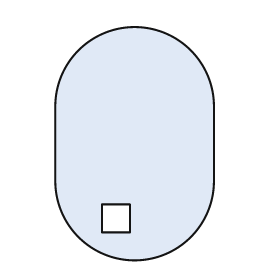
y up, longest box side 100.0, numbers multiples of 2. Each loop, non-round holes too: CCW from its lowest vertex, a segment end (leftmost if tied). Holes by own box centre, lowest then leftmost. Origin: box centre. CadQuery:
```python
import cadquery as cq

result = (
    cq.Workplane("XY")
    .moveTo(-34.0, -16.0)
    .threePointArc((0.0, -50.0), (34.0, -16.0))
    .lineTo(34.0, 16.0)
    .threePointArc((0.0, 50.0), (-34.0, 16.0))
    .close()
    .moveTo(-14.0, -38.0)
    .lineTo(-2.0, -38.0)
    .lineTo(-2.0, -26.0)
    .lineTo(-14.0, -26.0)
    .close()
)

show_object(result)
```